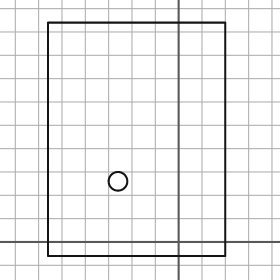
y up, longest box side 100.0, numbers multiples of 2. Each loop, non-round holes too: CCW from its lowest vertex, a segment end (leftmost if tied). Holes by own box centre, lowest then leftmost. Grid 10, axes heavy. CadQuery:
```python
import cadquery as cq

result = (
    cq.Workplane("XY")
    .moveTo(-56.0, -6.0)
    .lineTo(20.0, -6.0)
    .lineTo(20.0, 94.0)
    .lineTo(-56.0, 94.0)
    .close()
    .moveTo(-26.0, 26.0)
    .circle(4.0)
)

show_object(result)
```